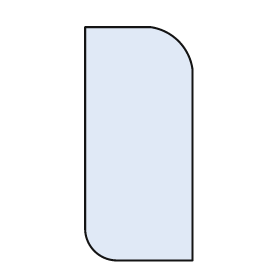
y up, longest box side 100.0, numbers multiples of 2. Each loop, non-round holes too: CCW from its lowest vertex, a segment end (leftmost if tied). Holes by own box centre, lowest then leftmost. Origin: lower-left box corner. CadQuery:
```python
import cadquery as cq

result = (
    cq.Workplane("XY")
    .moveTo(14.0, 0.0)
    .lineTo(46.0, 0.0)
    .lineTo(46.0, 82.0)
    .threePointArc((40.0, 94.0), (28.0, 100.0))
    .lineTo(0.0, 100.0)
    .lineTo(0.0, 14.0)
    .threePointArc((4.0, 4.0), (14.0, 0.0))
    .close()
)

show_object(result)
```